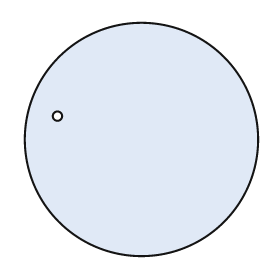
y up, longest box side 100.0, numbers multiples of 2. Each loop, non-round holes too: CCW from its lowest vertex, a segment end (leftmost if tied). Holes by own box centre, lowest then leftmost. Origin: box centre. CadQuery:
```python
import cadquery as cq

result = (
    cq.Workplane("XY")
    .moveTo(0.0, 0.0)
    .circle(50.0)
    .moveTo(-36.0, 10.0)
    .circle(2.0)
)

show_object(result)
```